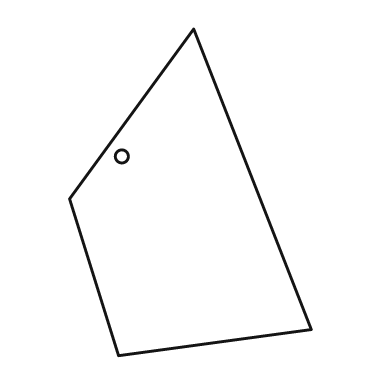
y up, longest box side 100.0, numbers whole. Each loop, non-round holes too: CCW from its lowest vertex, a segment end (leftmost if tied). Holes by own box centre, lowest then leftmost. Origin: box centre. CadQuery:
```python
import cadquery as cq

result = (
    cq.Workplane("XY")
    .moveTo(-22.0, -50.0)
    .lineTo(37.0, -42.0)
    .lineTo(1.0, 50.0)
    .lineTo(-37.0, -2.0)
    .close()
    .moveTo(-21.0, 11.0)
    .circle(2.0)
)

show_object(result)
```